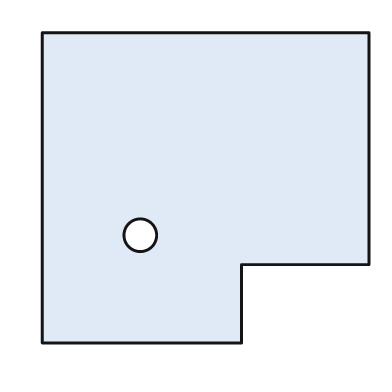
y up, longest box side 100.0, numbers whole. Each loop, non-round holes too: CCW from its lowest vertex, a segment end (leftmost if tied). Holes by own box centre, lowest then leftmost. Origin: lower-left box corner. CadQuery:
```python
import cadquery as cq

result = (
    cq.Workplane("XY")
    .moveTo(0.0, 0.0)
    .lineTo(61.0, 0.0)
    .lineTo(61.0, 24.0)
    .lineTo(100.0, 24.0)
    .lineTo(100.0, 95.0)
    .lineTo(0.0, 95.0)
    .close()
    .moveTo(30.0, 33.0)
    .circle(5.0)
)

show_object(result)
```